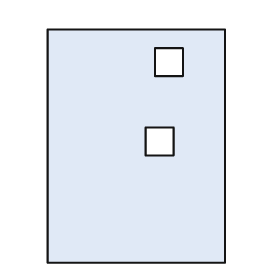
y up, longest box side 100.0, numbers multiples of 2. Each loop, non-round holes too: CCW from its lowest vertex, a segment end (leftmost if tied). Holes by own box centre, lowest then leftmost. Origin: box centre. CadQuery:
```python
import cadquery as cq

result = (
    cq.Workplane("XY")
    .moveTo(-38.0, -50.0)
    .lineTo(38.0, -50.0)
    .lineTo(38.0, 50.0)
    .lineTo(-38.0, 50.0)
    .close()
    .moveTo(4.0, -4.0)
    .lineTo(16.0, -4.0)
    .lineTo(16.0, 8.0)
    .lineTo(4.0, 8.0)
    .close()
    .moveTo(8.0, 30.0)
    .lineTo(20.0, 30.0)
    .lineTo(20.0, 42.0)
    .lineTo(8.0, 42.0)
    .close()
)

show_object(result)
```